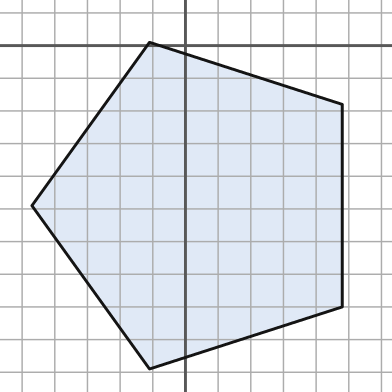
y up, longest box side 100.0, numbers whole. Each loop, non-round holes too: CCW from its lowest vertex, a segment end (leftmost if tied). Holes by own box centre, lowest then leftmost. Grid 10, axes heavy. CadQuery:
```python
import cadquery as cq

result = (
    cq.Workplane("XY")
    .moveTo(-11.0, -99.0)
    .lineTo(48.0, -80.0)
    .lineTo(48.0, -18.0)
    .lineTo(-11.0, 1.0)
    .lineTo(-47.0, -49.0)
    .close()
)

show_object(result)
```